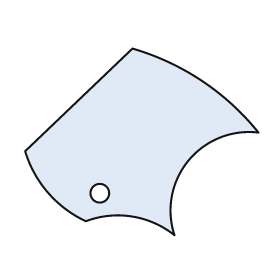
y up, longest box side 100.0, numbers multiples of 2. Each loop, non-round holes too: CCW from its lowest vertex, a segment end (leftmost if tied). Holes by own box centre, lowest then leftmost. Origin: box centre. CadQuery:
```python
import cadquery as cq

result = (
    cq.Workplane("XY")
    .moveTo(14.0, -40.0)
    .threePointArc((20.0, -8.0), (50.0, 4.0))
    .threePointArc((26.0, 26.0), (-4.0, 40.0))
    .lineTo(-50.0, -4.0)
    .threePointArc((-40.0, -22.0), (-24.0, -34.0))
    .threePointArc((-4.0, -32.0), (14.0, -40.0))
    .close()
    .moveTo(-18.0, -22.0)
    .circle(4.0)
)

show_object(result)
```